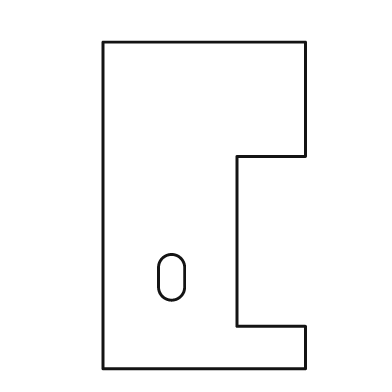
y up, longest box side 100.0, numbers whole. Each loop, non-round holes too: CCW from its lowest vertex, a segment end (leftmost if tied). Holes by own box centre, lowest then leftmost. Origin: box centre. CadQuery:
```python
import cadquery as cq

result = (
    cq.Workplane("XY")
    .moveTo(-31.0, -50.0)
    .lineTo(31.0, -50.0)
    .lineTo(31.0, -37.0)
    .lineTo(10.0, -37.0)
    .lineTo(10.0, 15.0)
    .lineTo(31.0, 15.0)
    .lineTo(31.0, 50.0)
    .lineTo(-31.0, 50.0)
    .close()
    .moveTo(-14.0, -25.0)
    .threePointArc((-10.0, -29.0), (-6.0, -25.0))
    .lineTo(-6.0, -19.0)
    .threePointArc((-10.0, -15.0), (-14.0, -19.0))
    .close()
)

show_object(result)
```